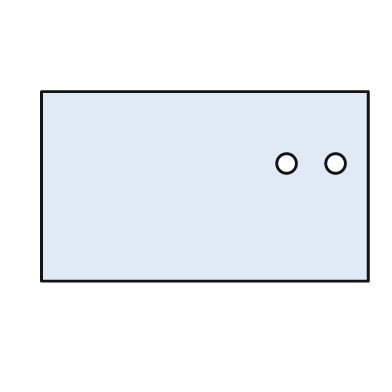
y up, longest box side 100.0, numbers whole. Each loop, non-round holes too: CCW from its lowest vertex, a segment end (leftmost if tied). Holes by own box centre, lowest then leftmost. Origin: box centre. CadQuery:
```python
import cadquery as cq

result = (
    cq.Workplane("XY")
    .moveTo(-50.0, -29.0)
    .lineTo(50.0, -29.0)
    .lineTo(50.0, 29.0)
    .lineTo(-50.0, 29.0)
    .close()
    .moveTo(25.0, 7.0)
    .circle(3.0)
    .moveTo(40.0, 7.0)
    .circle(3.0)
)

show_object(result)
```